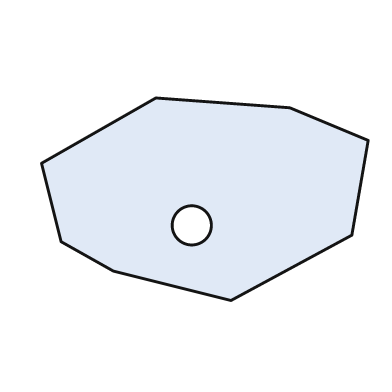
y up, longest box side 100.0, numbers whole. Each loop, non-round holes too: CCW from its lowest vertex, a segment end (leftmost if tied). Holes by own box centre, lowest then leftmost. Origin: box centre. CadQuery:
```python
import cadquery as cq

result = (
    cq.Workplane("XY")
    .moveTo(8.0, -31.0)
    .lineTo(45.0, -11.0)
    .lineTo(50.0, 18.0)
    .lineTo(26.0, 28.0)
    .lineTo(-15.0, 31.0)
    .lineTo(-50.0, 11.0)
    .lineTo(-44.0, -13.0)
    .lineTo(-28.0, -22.0)
    .close()
    .moveTo(-4.0, -8.0)
    .circle(6.0)
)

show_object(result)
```